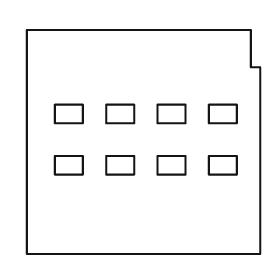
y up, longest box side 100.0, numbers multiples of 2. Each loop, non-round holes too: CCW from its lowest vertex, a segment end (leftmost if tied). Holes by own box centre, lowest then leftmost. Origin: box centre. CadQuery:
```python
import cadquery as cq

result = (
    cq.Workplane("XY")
    .moveTo(-50.0, -48.0)
    .lineTo(50.0, -48.0)
    .lineTo(50.0, 32.0)
    .lineTo(46.0, 32.0)
    .lineTo(46.0, 48.0)
    .lineTo(-50.0, 48.0)
    .close()
    .moveTo(-38.0, -14.0)
    .lineTo(-26.0, -14.0)
    .lineTo(-26.0, -6.0)
    .lineTo(-38.0, -6.0)
    .close()
    .moveTo(-16.0, -14.0)
    .lineTo(-4.0, -14.0)
    .lineTo(-4.0, -6.0)
    .lineTo(-16.0, -6.0)
    .close()
    .moveTo(6.0, -14.0)
    .lineTo(18.0, -14.0)
    .lineTo(18.0, -6.0)
    .lineTo(6.0, -6.0)
    .close()
    .moveTo(28.0, -14.0)
    .lineTo(40.0, -14.0)
    .lineTo(40.0, -6.0)
    .lineTo(28.0, -6.0)
    .close()
    .moveTo(-38.0, 8.0)
    .lineTo(-26.0, 8.0)
    .lineTo(-26.0, 16.0)
    .lineTo(-38.0, 16.0)
    .close()
    .moveTo(-16.0, 8.0)
    .lineTo(-4.0, 8.0)
    .lineTo(-4.0, 16.0)
    .lineTo(-16.0, 16.0)
    .close()
    .moveTo(6.0, 8.0)
    .lineTo(18.0, 8.0)
    .lineTo(18.0, 16.0)
    .lineTo(6.0, 16.0)
    .close()
    .moveTo(28.0, 8.0)
    .lineTo(40.0, 8.0)
    .lineTo(40.0, 16.0)
    .lineTo(28.0, 16.0)
    .close()
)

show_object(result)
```